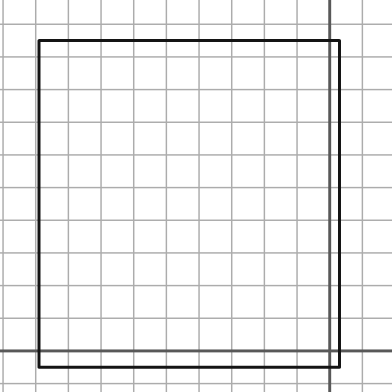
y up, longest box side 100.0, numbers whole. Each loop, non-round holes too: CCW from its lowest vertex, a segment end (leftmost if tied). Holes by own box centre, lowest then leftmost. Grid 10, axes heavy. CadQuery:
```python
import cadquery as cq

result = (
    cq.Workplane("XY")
    .moveTo(-89.0, -5.0)
    .lineTo(3.0, -5.0)
    .lineTo(3.0, 95.0)
    .lineTo(-89.0, 95.0)
    .close()
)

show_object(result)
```